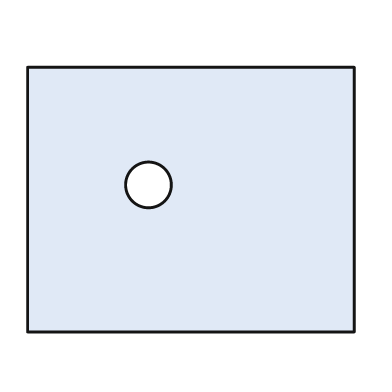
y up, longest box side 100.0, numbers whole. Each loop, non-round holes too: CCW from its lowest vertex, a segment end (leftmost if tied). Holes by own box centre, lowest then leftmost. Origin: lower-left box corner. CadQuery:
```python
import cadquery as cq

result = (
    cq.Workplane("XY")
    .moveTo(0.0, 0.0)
    .lineTo(100.0, 0.0)
    .lineTo(100.0, 81.0)
    .lineTo(0.0, 81.0)
    .close()
    .moveTo(37.0, 45.0)
    .circle(7.0)
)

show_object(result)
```